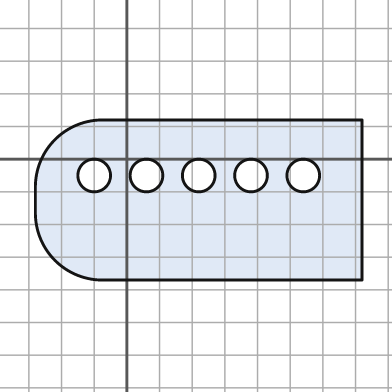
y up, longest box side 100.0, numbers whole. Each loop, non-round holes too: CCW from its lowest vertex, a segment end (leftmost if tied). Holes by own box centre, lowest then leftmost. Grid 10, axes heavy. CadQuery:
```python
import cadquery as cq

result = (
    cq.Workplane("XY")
    .moveTo(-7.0, -37.0)
    .lineTo(72.0, -37.0)
    .lineTo(72.0, 12.0)
    .lineTo(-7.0, 12.0)
    .threePointArc((-22.0, 6.0), (-28.0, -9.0))
    .lineTo(-28.0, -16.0)
    .threePointArc((-22.0, -31.0), (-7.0, -37.0))
    .close()
    .moveTo(-10.0, -5.0)
    .circle(5.0)
    .moveTo(6.0, -5.0)
    .circle(5.0)
    .moveTo(22.0, -5.0)
    .circle(5.0)
    .moveTo(38.0, -5.0)
    .circle(5.0)
    .moveTo(54.0, -5.0)
    .circle(5.0)
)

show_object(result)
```